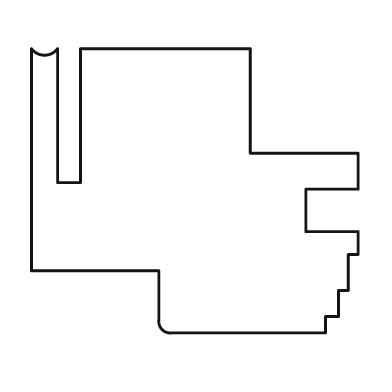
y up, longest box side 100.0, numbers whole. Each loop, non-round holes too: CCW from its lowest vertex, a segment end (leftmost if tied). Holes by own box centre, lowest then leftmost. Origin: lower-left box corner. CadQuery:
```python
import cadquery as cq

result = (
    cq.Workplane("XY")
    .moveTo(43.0, 0.0)
    .lineTo(90.0, 0.0)
    .lineTo(90.0, 5.0)
    .lineTo(94.0, 5.0)
    .lineTo(94.0, 13.0)
    .lineTo(97.0, 13.0)
    .lineTo(97.0, 24.0)
    .lineTo(100.0, 24.0)
    .lineTo(100.0, 31.0)
    .lineTo(84.0, 31.0)
    .lineTo(84.0, 44.0)
    .lineTo(100.0, 44.0)
    .lineTo(100.0, 55.0)
    .lineTo(67.0, 55.0)
    .lineTo(67.0, 87.0)
    .lineTo(15.0, 87.0)
    .lineTo(15.0, 46.0)
    .lineTo(8.0, 46.0)
    .lineTo(8.0, 87.0)
    .threePointArc((4.0, 85.0), (0.0, 87.0))
    .lineTo(0.0, 19.0)
    .lineTo(39.0, 19.0)
    .lineTo(39.0, 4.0)
    .threePointArc((40.0, 1.0), (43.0, 0.0))
    .close()
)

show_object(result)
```